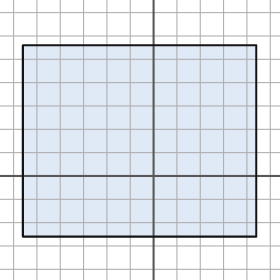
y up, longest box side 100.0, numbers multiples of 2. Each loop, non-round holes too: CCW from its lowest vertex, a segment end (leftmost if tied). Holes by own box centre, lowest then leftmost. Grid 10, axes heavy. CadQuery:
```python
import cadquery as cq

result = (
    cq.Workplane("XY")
    .moveTo(-56.0, -26.0)
    .lineTo(44.0, -26.0)
    .lineTo(44.0, 56.0)
    .lineTo(-56.0, 56.0)
    .close()
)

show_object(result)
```